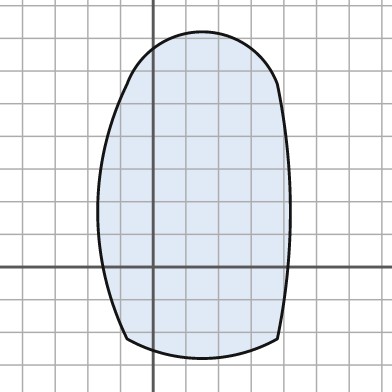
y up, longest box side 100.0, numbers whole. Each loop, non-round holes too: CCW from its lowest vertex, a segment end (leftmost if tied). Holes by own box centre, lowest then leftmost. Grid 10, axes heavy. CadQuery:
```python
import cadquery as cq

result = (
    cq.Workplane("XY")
    .moveTo(-8.0, -22.0)
    .threePointArc((15.0, -28.0), (38.0, -22.0))
    .threePointArc((42.0, 17.0), (38.0, 56.0))
    .threePointArc((15.0, 72.0), (-8.0, 56.0))
    .threePointArc((-17.0, 17.0), (-8.0, -22.0))
    .close()
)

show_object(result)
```